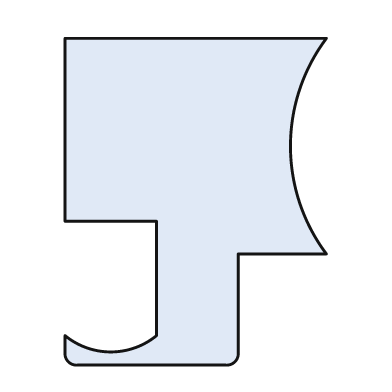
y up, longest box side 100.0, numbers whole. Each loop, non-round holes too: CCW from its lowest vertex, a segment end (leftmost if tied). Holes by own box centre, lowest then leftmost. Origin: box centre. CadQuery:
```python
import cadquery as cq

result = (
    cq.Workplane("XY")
    .moveTo(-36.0, -50.0)
    .lineTo(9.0, -50.0)
    .threePointArc((12.0, -49.0), (13.0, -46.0))
    .lineTo(13.0, -16.0)
    .lineTo(40.0, -16.0)
    .threePointArc((29.0, 17.0), (40.0, 50.0))
    .lineTo(-40.0, 50.0)
    .lineTo(-40.0, -6.0)
    .lineTo(-12.0, -6.0)
    .lineTo(-12.0, -41.0)
    .threePointArc((-26.0, -46.0), (-40.0, -41.0))
    .lineTo(-40.0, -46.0)
    .threePointArc((-39.0, -49.0), (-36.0, -50.0))
    .close()
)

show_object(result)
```